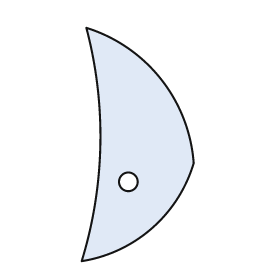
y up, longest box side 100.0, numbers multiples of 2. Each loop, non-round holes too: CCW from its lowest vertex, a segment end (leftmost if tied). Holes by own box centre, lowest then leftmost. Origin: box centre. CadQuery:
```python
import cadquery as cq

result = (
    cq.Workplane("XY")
    .moveTo(-24.0, -50.0)
    .threePointArc((6.0, -36.0), (24.0, -8.0))
    .threePointArc((10.0, 28.0), (-22.0, 50.0))
    .threePointArc((-16.0, 0.0), (-24.0, -50.0))
    .close()
    .moveTo(-4.0, -16.0)
    .circle(4.0)
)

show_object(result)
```